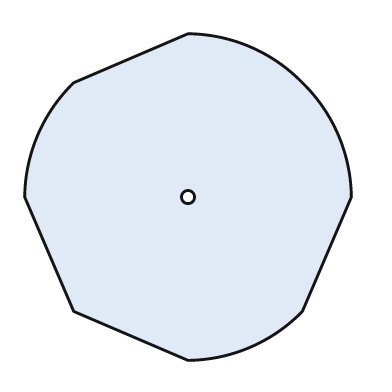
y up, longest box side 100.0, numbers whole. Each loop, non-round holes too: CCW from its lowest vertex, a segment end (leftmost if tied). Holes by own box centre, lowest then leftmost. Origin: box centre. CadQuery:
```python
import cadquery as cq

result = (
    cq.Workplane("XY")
    .moveTo(0.0, -50.0)
    .threePointArc((19.0, -46.0), (35.0, -35.0))
    .lineTo(50.0, 0.0)
    .threePointArc((46.0, 19.0), (35.0, 35.0))
    .threePointArc((19.0, 46.0), (0.0, 50.0))
    .lineTo(-35.0, 35.0)
    .threePointArc((-46.0, 19.0), (-50.0, 0.0))
    .lineTo(-35.0, -35.0)
    .close()
    .moveTo(0.0, 0.0)
    .circle(2.0)
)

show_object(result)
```